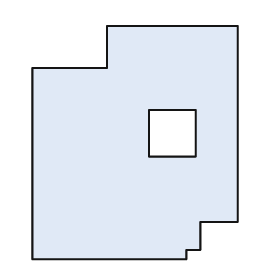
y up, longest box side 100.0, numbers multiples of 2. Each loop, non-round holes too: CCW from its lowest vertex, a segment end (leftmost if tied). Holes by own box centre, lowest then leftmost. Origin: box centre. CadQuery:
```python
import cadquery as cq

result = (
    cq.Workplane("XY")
    .moveTo(-44.0, -50.0)
    .lineTo(22.0, -50.0)
    .lineTo(22.0, -46.0)
    .lineTo(28.0, -46.0)
    .lineTo(28.0, -34.0)
    .lineTo(44.0, -34.0)
    .lineTo(44.0, 50.0)
    .lineTo(-12.0, 50.0)
    .lineTo(-12.0, 32.0)
    .lineTo(-44.0, 32.0)
    .close()
    .moveTo(6.0, -6.0)
    .lineTo(26.0, -6.0)
    .lineTo(26.0, 14.0)
    .lineTo(6.0, 14.0)
    .close()
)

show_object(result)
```